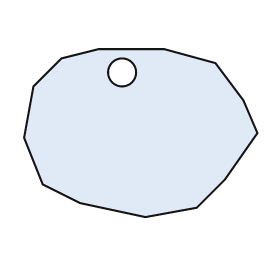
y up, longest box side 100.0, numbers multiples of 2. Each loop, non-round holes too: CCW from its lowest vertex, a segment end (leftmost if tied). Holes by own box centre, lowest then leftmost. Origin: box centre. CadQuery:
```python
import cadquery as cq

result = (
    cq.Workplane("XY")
    .moveTo(2.0, -36.0)
    .lineTo(24.0, -32.0)
    .lineTo(36.0, -20.0)
    .lineTo(50.0, 0.0)
    .lineTo(44.0, 14.0)
    .lineTo(32.0, 30.0)
    .lineTo(10.0, 36.0)
    .lineTo(-18.0, 36.0)
    .lineTo(-34.0, 32.0)
    .lineTo(-46.0, 20.0)
    .lineTo(-50.0, -2.0)
    .lineTo(-42.0, -22.0)
    .lineTo(-26.0, -30.0)
    .close()
    .moveTo(-8.0, 26.0)
    .circle(6.0)
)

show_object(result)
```